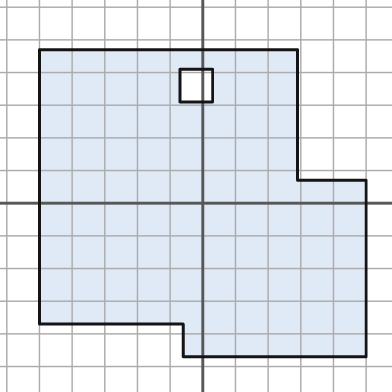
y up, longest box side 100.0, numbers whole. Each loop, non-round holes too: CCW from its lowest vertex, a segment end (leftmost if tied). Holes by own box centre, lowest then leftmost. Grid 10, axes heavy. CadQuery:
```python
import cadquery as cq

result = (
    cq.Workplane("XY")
    .moveTo(-6.0, -47.0)
    .lineTo(50.0, -47.0)
    .lineTo(50.0, 7.0)
    .lineTo(29.0, 7.0)
    .lineTo(29.0, 47.0)
    .lineTo(-50.0, 47.0)
    .lineTo(-50.0, -37.0)
    .lineTo(-6.0, -37.0)
    .close()
    .moveTo(-7.0, 31.0)
    .lineTo(3.0, 31.0)
    .lineTo(3.0, 41.0)
    .lineTo(-7.0, 41.0)
    .close()
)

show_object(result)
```